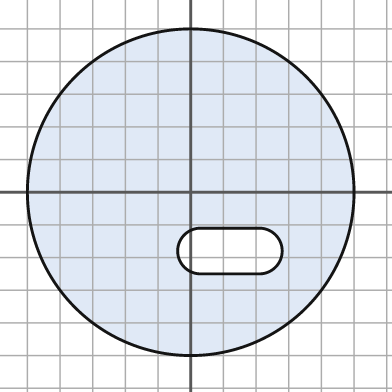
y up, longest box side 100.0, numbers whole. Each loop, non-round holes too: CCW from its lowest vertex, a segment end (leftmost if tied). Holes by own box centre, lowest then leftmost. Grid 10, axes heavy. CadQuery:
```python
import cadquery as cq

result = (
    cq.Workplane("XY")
    .moveTo(0.0, 0.0)
    .circle(50.0)
    .moveTo(3.0, -25.0)
    .lineTo(21.0, -25.0)
    .threePointArc((28.0, -18.0), (21.0, -11.0))
    .lineTo(3.0, -11.0)
    .threePointArc((-4.0, -18.0), (3.0, -25.0))
    .close()
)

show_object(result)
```